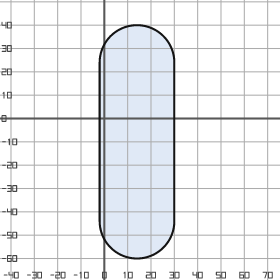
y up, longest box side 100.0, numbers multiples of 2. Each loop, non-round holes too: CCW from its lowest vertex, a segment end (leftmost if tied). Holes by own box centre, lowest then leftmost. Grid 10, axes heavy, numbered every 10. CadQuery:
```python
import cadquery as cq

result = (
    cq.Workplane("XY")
    .moveTo(-2.0, -44.0)
    .threePointArc((14.0, -60.0), (30.0, -44.0))
    .lineTo(30.0, 24.0)
    .threePointArc((14.0, 40.0), (-2.0, 24.0))
    .close()
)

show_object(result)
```